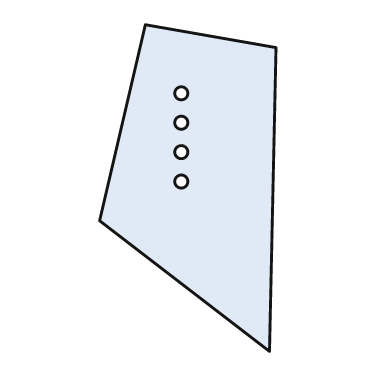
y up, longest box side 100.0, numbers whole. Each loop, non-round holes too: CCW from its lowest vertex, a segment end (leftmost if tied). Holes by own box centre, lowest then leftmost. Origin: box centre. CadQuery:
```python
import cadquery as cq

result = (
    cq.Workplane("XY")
    .moveTo(25.0, -50.0)
    .lineTo(27.0, 43.0)
    .lineTo(-13.0, 50.0)
    .lineTo(-27.0, -10.0)
    .close()
    .moveTo(-2.0, 2.0)
    .circle(2.0)
    .moveTo(-2.0, 11.0)
    .circle(2.0)
    .moveTo(-2.0, 20.0)
    .circle(2.0)
    .moveTo(-2.0, 29.0)
    .circle(2.0)
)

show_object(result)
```